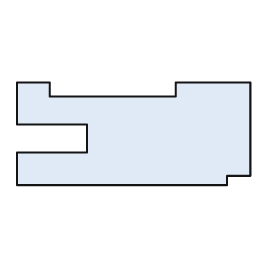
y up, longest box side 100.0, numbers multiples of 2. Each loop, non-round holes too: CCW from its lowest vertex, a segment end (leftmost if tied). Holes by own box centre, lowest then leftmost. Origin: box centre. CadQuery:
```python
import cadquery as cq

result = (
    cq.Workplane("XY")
    .moveTo(-50.0, -22.0)
    .lineTo(40.0, -22.0)
    .lineTo(40.0, -18.0)
    .lineTo(50.0, -18.0)
    .lineTo(50.0, 22.0)
    .lineTo(18.0, 22.0)
    .lineTo(18.0, 16.0)
    .lineTo(-36.0, 16.0)
    .lineTo(-36.0, 22.0)
    .lineTo(-50.0, 22.0)
    .lineTo(-50.0, 4.0)
    .lineTo(-20.0, 4.0)
    .lineTo(-20.0, -8.0)
    .lineTo(-50.0, -8.0)
    .close()
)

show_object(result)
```